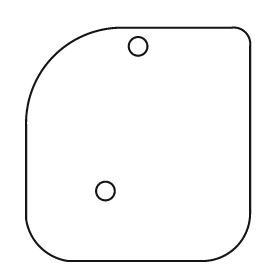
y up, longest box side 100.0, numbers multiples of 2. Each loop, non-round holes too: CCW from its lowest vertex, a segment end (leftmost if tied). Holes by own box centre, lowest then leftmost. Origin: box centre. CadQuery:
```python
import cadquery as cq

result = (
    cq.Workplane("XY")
    .moveTo(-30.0, -50.0)
    .lineTo(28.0, -50.0)
    .threePointArc((42.0, -44.0), (48.0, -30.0))
    .lineTo(48.0, 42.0)
    .threePointArc((46.0, 48.0), (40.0, 50.0))
    .lineTo(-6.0, 50.0)
    .threePointArc((-36.0, 38.0), (-48.0, 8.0))
    .lineTo(-48.0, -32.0)
    .threePointArc((-42.0, -44.0), (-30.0, -50.0))
    .close()
    .moveTo(-14.0, -20.0)
    .circle(4.0)
    .moveTo(0.0, 42.0)
    .circle(4.0)
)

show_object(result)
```